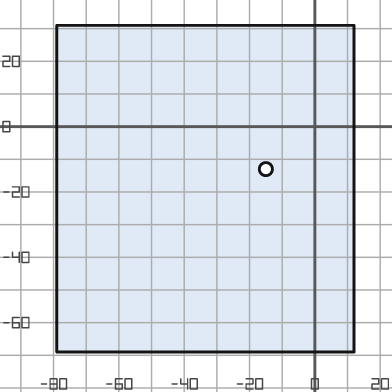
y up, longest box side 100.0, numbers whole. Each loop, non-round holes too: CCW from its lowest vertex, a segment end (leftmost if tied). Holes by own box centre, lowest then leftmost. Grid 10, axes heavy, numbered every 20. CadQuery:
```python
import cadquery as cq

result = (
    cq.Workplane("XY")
    .moveTo(-79.0, -69.0)
    .lineTo(12.0, -69.0)
    .lineTo(12.0, 31.0)
    .lineTo(-79.0, 31.0)
    .close()
    .moveTo(-15.0, -13.0)
    .circle(2.0)
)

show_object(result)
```